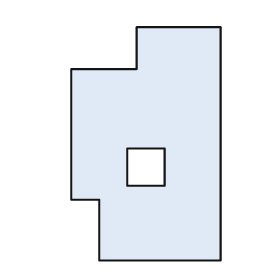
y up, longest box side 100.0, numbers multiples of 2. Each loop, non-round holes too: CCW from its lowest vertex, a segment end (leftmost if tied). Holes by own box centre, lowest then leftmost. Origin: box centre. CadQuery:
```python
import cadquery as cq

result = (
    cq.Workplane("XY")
    .moveTo(-20.0, -50.0)
    .lineTo(32.0, -50.0)
    .lineTo(32.0, 50.0)
    .lineTo(-4.0, 50.0)
    .lineTo(-4.0, 32.0)
    .lineTo(-32.0, 32.0)
    .lineTo(-32.0, -24.0)
    .lineTo(-20.0, -24.0)
    .close()
    .moveTo(-8.0, -18.0)
    .lineTo(8.0, -18.0)
    .lineTo(8.0, -2.0)
    .lineTo(-8.0, -2.0)
    .close()
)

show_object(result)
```